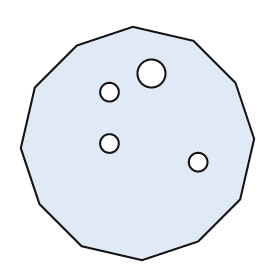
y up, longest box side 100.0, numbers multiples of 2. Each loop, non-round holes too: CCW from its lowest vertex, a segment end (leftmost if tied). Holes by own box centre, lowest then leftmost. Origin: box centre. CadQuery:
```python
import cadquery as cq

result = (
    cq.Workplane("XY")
    .moveTo(2.0, -50.0)
    .lineTo(26.0, -42.0)
    .lineTo(44.0, -24.0)
    .lineTo(50.0, 2.0)
    .lineTo(42.0, 26.0)
    .lineTo(24.0, 44.0)
    .lineTo(-2.0, 50.0)
    .lineTo(-26.0, 42.0)
    .lineTo(-44.0, 24.0)
    .lineTo(-50.0, -2.0)
    .lineTo(-42.0, -26.0)
    .lineTo(-24.0, -44.0)
    .close()
    .moveTo(26.0, -8.0)
    .circle(4.0)
    .moveTo(-12.0, 0.0)
    .circle(4.0)
    .moveTo(-12.0, 22.0)
    .circle(4.0)
    .moveTo(6.0, 30.0)
    .circle(6.0)
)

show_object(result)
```